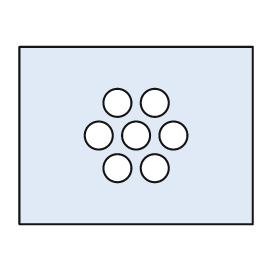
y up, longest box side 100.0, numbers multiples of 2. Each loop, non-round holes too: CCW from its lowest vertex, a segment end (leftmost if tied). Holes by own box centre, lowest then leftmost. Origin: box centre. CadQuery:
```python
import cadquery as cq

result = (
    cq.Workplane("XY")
    .moveTo(-50.0, -38.0)
    .lineTo(50.0, -38.0)
    .lineTo(50.0, 38.0)
    .lineTo(-50.0, 38.0)
    .close()
    .moveTo(-8.0, -14.0)
    .circle(6.0)
    .moveTo(8.0, -14.0)
    .circle(6.0)
    .moveTo(-16.0, 0.0)
    .circle(6.0)
    .moveTo(0.0, 0.0)
    .circle(6.0)
    .moveTo(16.0, 0.0)
    .circle(6.0)
    .moveTo(-8.0, 14.0)
    .circle(6.0)
    .moveTo(8.0, 14.0)
    .circle(6.0)
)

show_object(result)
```